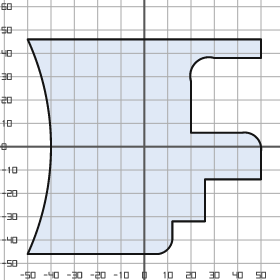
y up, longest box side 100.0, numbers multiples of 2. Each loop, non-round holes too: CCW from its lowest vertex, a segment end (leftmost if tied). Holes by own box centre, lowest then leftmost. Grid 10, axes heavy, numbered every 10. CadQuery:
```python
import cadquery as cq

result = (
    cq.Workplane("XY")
    .moveTo(-50.0, -46.0)
    .lineTo(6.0, -46.0)
    .threePointArc((10.0, -44.0), (12.0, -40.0))
    .lineTo(12.0, -32.0)
    .lineTo(26.0, -32.0)
    .lineTo(26.0, -14.0)
    .lineTo(50.0, -14.0)
    .lineTo(50.0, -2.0)
    .threePointArc((48.0, 4.0), (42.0, 6.0))
    .lineTo(20.0, 6.0)
    .lineTo(20.0, 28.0)
    .threePointArc((22.0, 36.0), (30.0, 38.0))
    .lineTo(50.0, 38.0)
    .lineTo(50.0, 46.0)
    .lineTo(-50.0, 46.0)
    .threePointArc((-40.0, 0.0), (-50.0, -46.0))
    .close()
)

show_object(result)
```